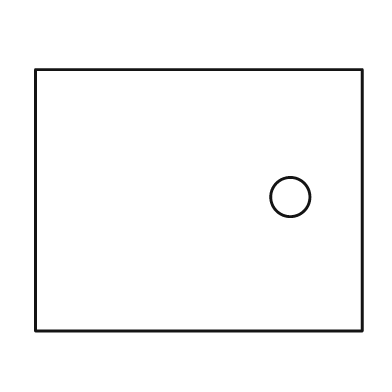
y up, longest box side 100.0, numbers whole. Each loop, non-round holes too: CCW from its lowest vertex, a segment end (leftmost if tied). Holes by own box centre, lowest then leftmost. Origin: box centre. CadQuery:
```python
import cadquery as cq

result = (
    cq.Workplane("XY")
    .moveTo(-50.0, -40.0)
    .lineTo(50.0, -40.0)
    .lineTo(50.0, 40.0)
    .lineTo(-50.0, 40.0)
    .close()
    .moveTo(28.0, 1.0)
    .circle(6.0)
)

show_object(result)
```